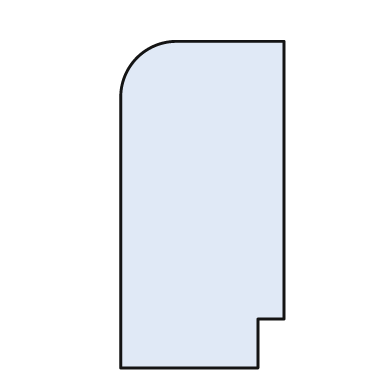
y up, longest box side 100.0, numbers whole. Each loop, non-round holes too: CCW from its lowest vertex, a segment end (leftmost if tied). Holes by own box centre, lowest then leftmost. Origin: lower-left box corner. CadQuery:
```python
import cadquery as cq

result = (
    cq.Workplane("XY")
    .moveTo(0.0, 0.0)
    .lineTo(42.0, 0.0)
    .lineTo(42.0, 15.0)
    .lineTo(50.0, 15.0)
    .lineTo(50.0, 100.0)
    .lineTo(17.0, 100.0)
    .threePointArc((5.0, 95.0), (0.0, 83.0))
    .close()
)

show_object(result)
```